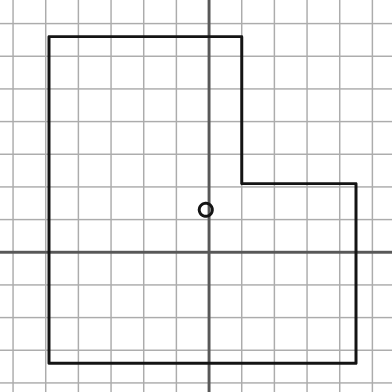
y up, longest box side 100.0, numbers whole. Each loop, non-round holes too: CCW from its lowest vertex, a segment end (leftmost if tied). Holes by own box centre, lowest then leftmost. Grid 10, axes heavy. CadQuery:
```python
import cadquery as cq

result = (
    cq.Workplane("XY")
    .moveTo(-49.0, -34.0)
    .lineTo(45.0, -34.0)
    .lineTo(45.0, 21.0)
    .lineTo(10.0, 21.0)
    .lineTo(10.0, 66.0)
    .lineTo(-49.0, 66.0)
    .close()
    .moveTo(-1.0, 13.0)
    .circle(2.0)
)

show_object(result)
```